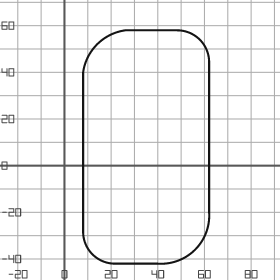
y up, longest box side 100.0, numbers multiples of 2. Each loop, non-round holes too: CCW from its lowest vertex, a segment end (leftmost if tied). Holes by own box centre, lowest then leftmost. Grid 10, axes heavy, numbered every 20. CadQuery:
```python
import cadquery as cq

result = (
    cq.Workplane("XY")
    .moveTo(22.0, -42.0)
    .lineTo(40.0, -42.0)
    .threePointArc((56.0, -36.0), (62.0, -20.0))
    .lineTo(62.0, 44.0)
    .threePointArc((58.0, 54.0), (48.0, 58.0))
    .lineTo(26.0, 58.0)
    .threePointArc((14.0, 52.0), (8.0, 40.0))
    .lineTo(8.0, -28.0)
    .threePointArc((12.0, -38.0), (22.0, -42.0))
    .close()
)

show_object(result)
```